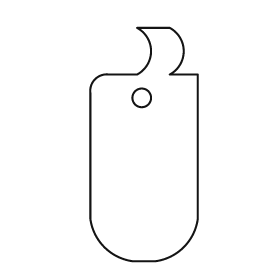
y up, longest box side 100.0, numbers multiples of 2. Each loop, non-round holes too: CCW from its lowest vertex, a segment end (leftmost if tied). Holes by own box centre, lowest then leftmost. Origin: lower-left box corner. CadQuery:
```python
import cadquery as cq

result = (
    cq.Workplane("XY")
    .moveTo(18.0, 0.0)
    .lineTo(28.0, 0.0)
    .threePointArc((40.0, 6.0), (46.0, 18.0))
    .lineTo(46.0, 80.0)
    .lineTo(34.0, 80.0)
    .threePointArc((40.0, 90.0), (34.0, 100.0))
    .lineTo(20.0, 100.0)
    .threePointArc((26.0, 90.0), (20.0, 80.0))
    .lineTo(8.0, 80.0)
    .threePointArc((2.0, 78.0), (0.0, 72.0))
    .lineTo(0.0, 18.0)
    .threePointArc((6.0, 6.0), (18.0, 0.0))
    .close()
    .moveTo(22.0, 70.0)
    .circle(4.0)
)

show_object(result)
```